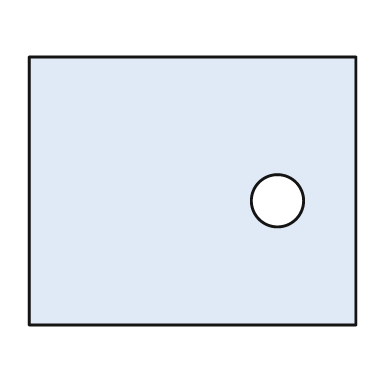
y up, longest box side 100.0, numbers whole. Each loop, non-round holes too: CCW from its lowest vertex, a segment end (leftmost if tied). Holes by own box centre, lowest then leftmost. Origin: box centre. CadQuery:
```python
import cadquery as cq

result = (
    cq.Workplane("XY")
    .moveTo(-50.0, -41.0)
    .lineTo(50.0, -41.0)
    .lineTo(50.0, 41.0)
    .lineTo(-50.0, 41.0)
    .close()
    .moveTo(26.0, -3.0)
    .circle(8.0)
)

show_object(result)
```